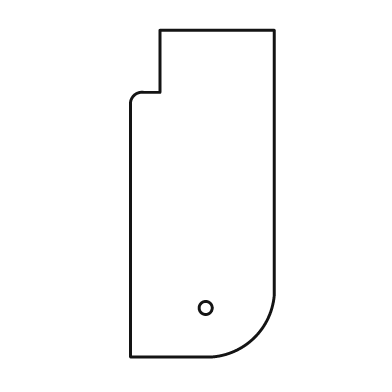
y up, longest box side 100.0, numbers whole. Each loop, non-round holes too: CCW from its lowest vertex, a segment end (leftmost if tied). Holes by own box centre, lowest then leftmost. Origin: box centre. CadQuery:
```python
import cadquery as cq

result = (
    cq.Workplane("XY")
    .moveTo(-22.0, -50.0)
    .lineTo(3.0, -50.0)
    .threePointArc((16.0, -44.0), (22.0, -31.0))
    .lineTo(22.0, 50.0)
    .lineTo(-13.0, 50.0)
    .lineTo(-13.0, 31.0)
    .lineTo(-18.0, 31.0)
    .threePointArc((-21.0, 30.0), (-22.0, 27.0))
    .close()
    .moveTo(1.0, -35.0)
    .circle(2.0)
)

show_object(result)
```